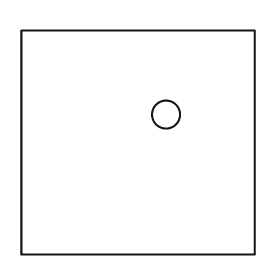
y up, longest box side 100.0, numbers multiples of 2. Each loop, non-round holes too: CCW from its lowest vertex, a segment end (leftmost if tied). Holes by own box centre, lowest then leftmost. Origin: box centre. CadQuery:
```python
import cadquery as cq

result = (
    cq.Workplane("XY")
    .moveTo(-50.0, -48.0)
    .lineTo(50.0, -48.0)
    .lineTo(50.0, 48.0)
    .lineTo(-50.0, 48.0)
    .close()
    .moveTo(12.0, 12.0)
    .circle(6.0)
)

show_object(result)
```